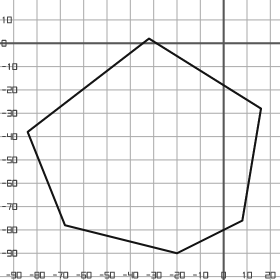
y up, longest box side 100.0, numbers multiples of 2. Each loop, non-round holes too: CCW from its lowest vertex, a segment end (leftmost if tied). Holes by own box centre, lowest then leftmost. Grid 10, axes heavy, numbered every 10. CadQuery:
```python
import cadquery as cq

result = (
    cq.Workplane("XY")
    .moveTo(-20.0, -90.0)
    .lineTo(8.0, -76.0)
    .lineTo(16.0, -28.0)
    .lineTo(-32.0, 2.0)
    .lineTo(-84.0, -38.0)
    .lineTo(-68.0, -78.0)
    .close()
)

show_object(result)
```